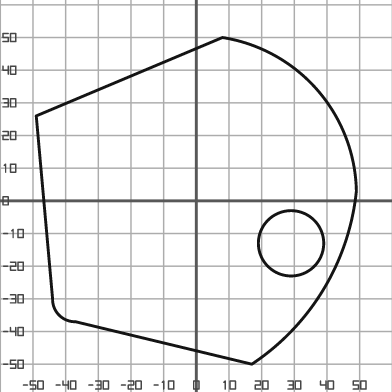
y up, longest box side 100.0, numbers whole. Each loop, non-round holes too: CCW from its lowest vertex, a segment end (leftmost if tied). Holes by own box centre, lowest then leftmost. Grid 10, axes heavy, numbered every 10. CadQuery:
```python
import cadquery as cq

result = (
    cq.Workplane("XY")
    .moveTo(17.0, -50.0)
    .threePointArc((39.0, -27.0), (49.0, 3.0))
    .threePointArc((37.0, 34.0), (8.0, 50.0))
    .lineTo(-49.0, 26.0)
    .lineTo(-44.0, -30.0)
    .threePointArc((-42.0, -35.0), (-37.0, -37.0))
    .close()
    .moveTo(29.0, -13.0)
    .circle(10.0)
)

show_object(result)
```